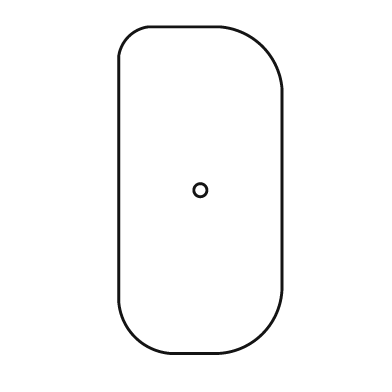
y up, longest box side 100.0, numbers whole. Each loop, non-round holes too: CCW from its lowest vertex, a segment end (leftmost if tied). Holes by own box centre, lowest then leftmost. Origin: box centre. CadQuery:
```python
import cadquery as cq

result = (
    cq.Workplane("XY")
    .moveTo(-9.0, -50.0)
    .lineTo(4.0, -50.0)
    .threePointArc((19.0, -44.0), (25.0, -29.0))
    .lineTo(25.0, 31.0)
    .threePointArc((19.0, 44.0), (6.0, 50.0))
    .lineTo(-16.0, 50.0)
    .threePointArc((-22.0, 47.0), (-25.0, 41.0))
    .lineTo(-25.0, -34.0)
    .threePointArc((-20.0, -45.0), (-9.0, -50.0))
    .close()
    .moveTo(0.0, 0.0)
    .circle(2.0)
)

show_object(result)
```